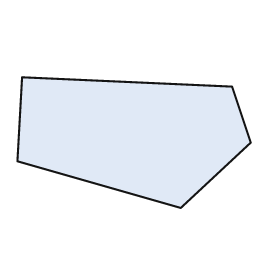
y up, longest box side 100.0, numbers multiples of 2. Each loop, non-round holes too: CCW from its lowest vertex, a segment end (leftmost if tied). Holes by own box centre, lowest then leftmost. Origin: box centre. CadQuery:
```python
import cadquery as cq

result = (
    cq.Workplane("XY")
    .moveTo(20.0, -28.0)
    .lineTo(50.0, 0.0)
    .lineTo(42.0, 24.0)
    .lineTo(-48.0, 28.0)
    .lineTo(-50.0, -8.0)
    .close()
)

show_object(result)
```